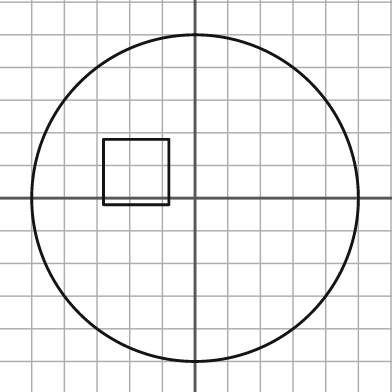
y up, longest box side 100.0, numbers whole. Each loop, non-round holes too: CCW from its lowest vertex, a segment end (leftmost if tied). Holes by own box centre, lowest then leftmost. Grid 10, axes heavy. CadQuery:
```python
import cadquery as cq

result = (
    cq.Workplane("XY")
    .moveTo(0.0, 0.0)
    .circle(50.0)
    .moveTo(-28.0, -2.0)
    .lineTo(-8.0, -2.0)
    .lineTo(-8.0, 18.0)
    .lineTo(-28.0, 18.0)
    .close()
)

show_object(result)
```